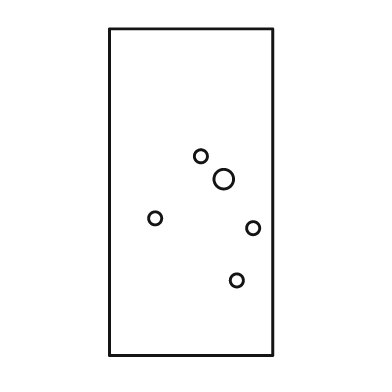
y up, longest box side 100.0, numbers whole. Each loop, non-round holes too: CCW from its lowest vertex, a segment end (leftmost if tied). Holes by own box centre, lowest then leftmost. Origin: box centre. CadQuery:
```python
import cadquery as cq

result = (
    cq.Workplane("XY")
    .moveTo(-25.0, -50.0)
    .lineTo(25.0, -50.0)
    .lineTo(25.0, 50.0)
    .lineTo(-25.0, 50.0)
    .close()
    .moveTo(14.0, -27.0)
    .circle(2.0)
    .moveTo(19.0, -11.0)
    .circle(2.0)
    .moveTo(-11.0, -8.0)
    .circle(2.0)
    .moveTo(10.0, 4.0)
    .circle(3.0)
    .moveTo(3.0, 11.0)
    .circle(2.0)
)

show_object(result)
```